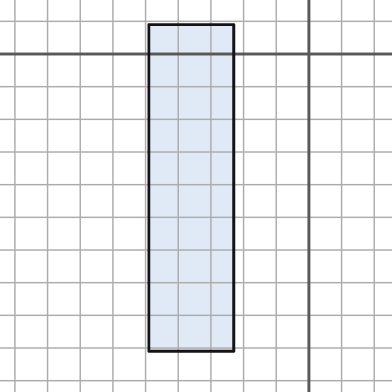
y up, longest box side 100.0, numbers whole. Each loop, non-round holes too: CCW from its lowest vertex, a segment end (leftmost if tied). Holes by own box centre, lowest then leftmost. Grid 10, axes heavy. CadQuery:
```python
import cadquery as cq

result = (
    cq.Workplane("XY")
    .moveTo(-49.0, -91.0)
    .lineTo(-23.0, -91.0)
    .lineTo(-23.0, 9.0)
    .lineTo(-49.0, 9.0)
    .close()
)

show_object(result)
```